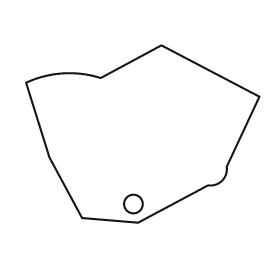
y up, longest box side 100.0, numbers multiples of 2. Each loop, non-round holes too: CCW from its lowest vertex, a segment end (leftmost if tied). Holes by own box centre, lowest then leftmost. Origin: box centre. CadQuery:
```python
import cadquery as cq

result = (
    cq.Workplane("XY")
    .moveTo(-2.0, -38.0)
    .lineTo(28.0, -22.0)
    .threePointArc((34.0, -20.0), (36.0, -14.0))
    .lineTo(50.0, 16.0)
    .lineTo(8.0, 38.0)
    .lineTo(-18.0, 24.0)
    .threePointArc((-34.0, 26.0), (-50.0, 22.0))
    .lineTo(-40.0, -10.0)
    .lineTo(-26.0, -36.0)
    .close()
    .moveTo(-4.0, -30.0)
    .circle(4.0)
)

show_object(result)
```